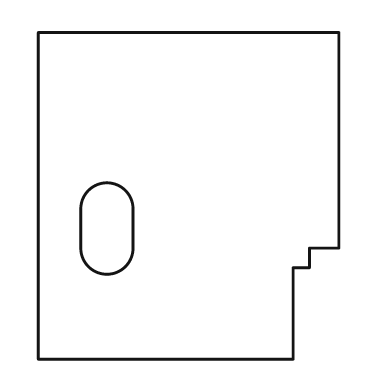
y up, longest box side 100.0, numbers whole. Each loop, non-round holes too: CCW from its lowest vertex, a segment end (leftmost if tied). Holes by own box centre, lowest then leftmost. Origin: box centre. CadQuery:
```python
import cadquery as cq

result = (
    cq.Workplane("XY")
    .moveTo(-46.0, -50.0)
    .lineTo(32.0, -50.0)
    .lineTo(32.0, -22.0)
    .lineTo(37.0, -22.0)
    .lineTo(37.0, -16.0)
    .lineTo(46.0, -16.0)
    .lineTo(46.0, 50.0)
    .lineTo(-46.0, 50.0)
    .close()
    .moveTo(-33.0, -16.0)
    .threePointArc((-25.0, -24.0), (-17.0, -16.0))
    .lineTo(-17.0, -4.0)
    .threePointArc((-25.0, 4.0), (-33.0, -4.0))
    .close()
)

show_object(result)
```